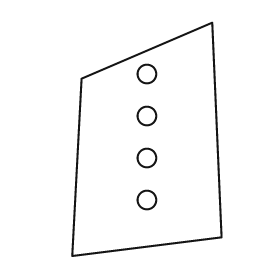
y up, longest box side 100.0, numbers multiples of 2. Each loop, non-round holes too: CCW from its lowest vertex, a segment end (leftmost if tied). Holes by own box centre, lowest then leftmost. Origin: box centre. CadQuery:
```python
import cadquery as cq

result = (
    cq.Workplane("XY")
    .moveTo(-32.0, -50.0)
    .lineTo(32.0, -42.0)
    .lineTo(28.0, 50.0)
    .lineTo(-28.0, 26.0)
    .close()
    .moveTo(0.0, -26.0)
    .circle(4.0)
    .moveTo(0.0, -8.0)
    .circle(4.0)
    .moveTo(0.0, 10.0)
    .circle(4.0)
    .moveTo(0.0, 28.0)
    .circle(4.0)
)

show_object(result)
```